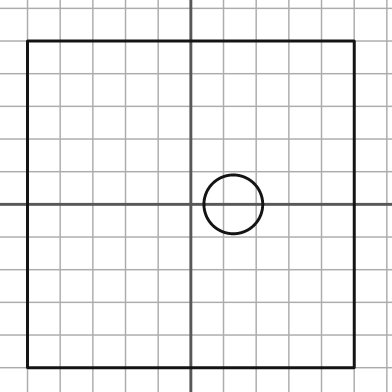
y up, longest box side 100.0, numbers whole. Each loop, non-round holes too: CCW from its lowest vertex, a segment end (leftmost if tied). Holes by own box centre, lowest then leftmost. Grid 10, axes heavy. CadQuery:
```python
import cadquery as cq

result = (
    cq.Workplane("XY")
    .moveTo(-50.0, -50.0)
    .lineTo(50.0, -50.0)
    .lineTo(50.0, 50.0)
    .lineTo(-50.0, 50.0)
    .close()
    .moveTo(13.0, 0.0)
    .circle(9.0)
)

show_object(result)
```